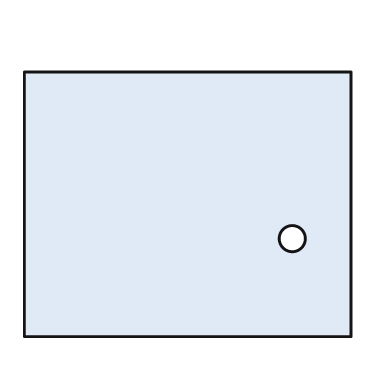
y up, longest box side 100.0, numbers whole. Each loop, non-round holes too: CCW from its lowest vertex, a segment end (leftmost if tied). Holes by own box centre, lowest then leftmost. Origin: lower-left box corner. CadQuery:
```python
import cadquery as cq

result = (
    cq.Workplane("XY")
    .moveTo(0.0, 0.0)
    .lineTo(100.0, 0.0)
    .lineTo(100.0, 81.0)
    .lineTo(0.0, 81.0)
    .close()
    .moveTo(82.0, 30.0)
    .circle(4.0)
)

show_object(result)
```